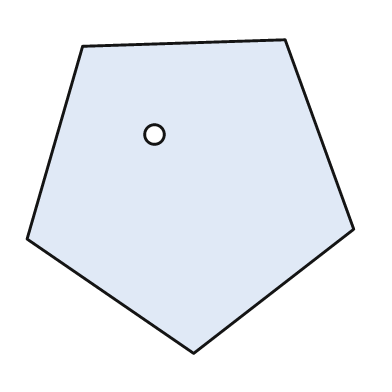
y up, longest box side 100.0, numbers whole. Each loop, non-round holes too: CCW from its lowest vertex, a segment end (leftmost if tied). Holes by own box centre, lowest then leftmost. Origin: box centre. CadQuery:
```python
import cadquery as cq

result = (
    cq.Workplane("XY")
    .moveTo(1.0, -48.0)
    .lineTo(50.0, -10.0)
    .lineTo(29.0, 48.0)
    .lineTo(-33.0, 46.0)
    .lineTo(-50.0, -13.0)
    .close()
    .moveTo(-11.0, 19.0)
    .circle(3.0)
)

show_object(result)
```